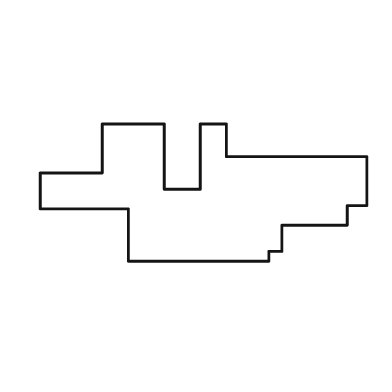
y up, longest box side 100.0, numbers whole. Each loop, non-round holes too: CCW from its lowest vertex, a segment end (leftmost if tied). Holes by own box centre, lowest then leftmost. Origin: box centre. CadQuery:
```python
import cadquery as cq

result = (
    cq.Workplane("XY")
    .moveTo(-23.0, -21.0)
    .lineTo(20.0, -21.0)
    .lineTo(20.0, -18.0)
    .lineTo(24.0, -18.0)
    .lineTo(24.0, -10.0)
    .lineTo(44.0, -10.0)
    .lineTo(44.0, -4.0)
    .lineTo(50.0, -4.0)
    .lineTo(50.0, 11.0)
    .lineTo(7.0, 11.0)
    .lineTo(7.0, 21.0)
    .lineTo(-1.0, 21.0)
    .lineTo(-1.0, 1.0)
    .lineTo(-12.0, 1.0)
    .lineTo(-12.0, 21.0)
    .lineTo(-31.0, 21.0)
    .lineTo(-31.0, 6.0)
    .lineTo(-50.0, 6.0)
    .lineTo(-50.0, -5.0)
    .lineTo(-23.0, -5.0)
    .close()
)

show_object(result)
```